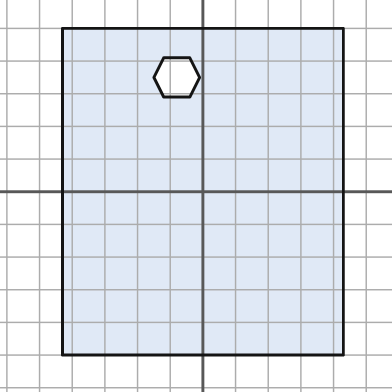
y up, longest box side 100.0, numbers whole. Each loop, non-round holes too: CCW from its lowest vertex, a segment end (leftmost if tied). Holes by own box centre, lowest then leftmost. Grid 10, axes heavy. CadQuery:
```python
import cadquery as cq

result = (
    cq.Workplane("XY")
    .moveTo(-43.0, -50.0)
    .lineTo(43.0, -50.0)
    .lineTo(43.0, 50.0)
    .lineTo(-43.0, 50.0)
    .close()
    .moveTo(-12.0, 29.0)
    .lineTo(-4.0, 29.0)
    .lineTo(-1.0, 35.0)
    .lineTo(-4.0, 41.0)
    .lineTo(-12.0, 41.0)
    .lineTo(-15.0, 35.0)
    .close()
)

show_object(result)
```